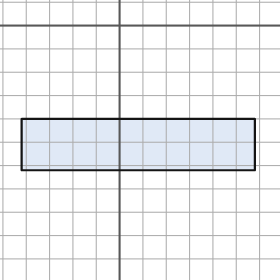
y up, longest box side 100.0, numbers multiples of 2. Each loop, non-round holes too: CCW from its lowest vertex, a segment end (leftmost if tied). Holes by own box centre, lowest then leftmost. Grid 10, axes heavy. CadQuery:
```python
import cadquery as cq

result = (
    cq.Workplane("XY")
    .moveTo(-42.0, -62.0)
    .lineTo(58.0, -62.0)
    .lineTo(58.0, -40.0)
    .lineTo(-42.0, -40.0)
    .close()
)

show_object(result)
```